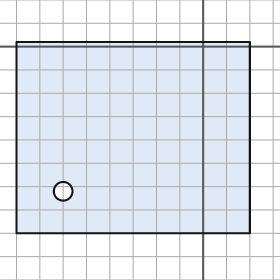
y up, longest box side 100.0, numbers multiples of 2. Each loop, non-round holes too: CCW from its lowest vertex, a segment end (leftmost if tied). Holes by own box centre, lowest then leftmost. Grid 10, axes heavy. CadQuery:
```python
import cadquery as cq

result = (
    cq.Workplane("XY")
    .moveTo(-80.0, -80.0)
    .lineTo(20.0, -80.0)
    .lineTo(20.0, 2.0)
    .lineTo(-80.0, 2.0)
    .close()
    .moveTo(-60.0, -62.0)
    .circle(4.0)
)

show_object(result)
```